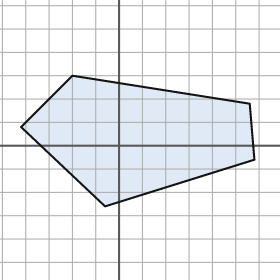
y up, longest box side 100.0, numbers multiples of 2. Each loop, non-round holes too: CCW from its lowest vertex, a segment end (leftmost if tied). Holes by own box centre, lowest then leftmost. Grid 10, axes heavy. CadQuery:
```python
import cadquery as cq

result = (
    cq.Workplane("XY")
    .moveTo(-6.0, -26.0)
    .lineTo(58.0, -6.0)
    .lineTo(56.0, 18.0)
    .lineTo(-20.0, 30.0)
    .lineTo(-42.0, 8.0)
    .close()
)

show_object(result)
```